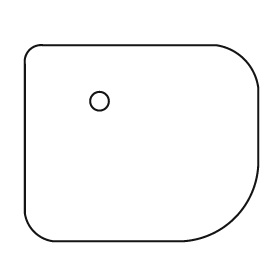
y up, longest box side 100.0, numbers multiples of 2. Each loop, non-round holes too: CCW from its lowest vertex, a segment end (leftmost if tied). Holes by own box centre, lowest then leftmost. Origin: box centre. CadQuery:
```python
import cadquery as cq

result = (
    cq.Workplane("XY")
    .moveTo(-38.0, -42.0)
    .lineTo(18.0, -42.0)
    .threePointArc((40.0, -32.0), (50.0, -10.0))
    .lineTo(50.0, 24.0)
    .threePointArc((44.0, 36.0), (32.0, 42.0))
    .lineTo(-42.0, 42.0)
    .threePointArc((-48.0, 40.0), (-50.0, 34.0))
    .lineTo(-50.0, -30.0)
    .threePointArc((-46.0, -38.0), (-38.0, -42.0))
    .close()
    .moveTo(-18.0, 18.0)
    .circle(4.0)
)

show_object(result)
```